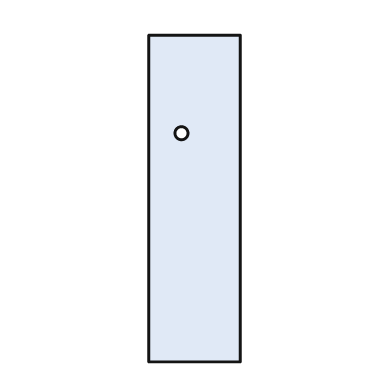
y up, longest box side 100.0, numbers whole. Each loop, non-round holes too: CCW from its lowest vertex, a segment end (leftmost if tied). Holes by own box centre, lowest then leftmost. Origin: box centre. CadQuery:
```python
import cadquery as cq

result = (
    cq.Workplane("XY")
    .moveTo(-14.0, -50.0)
    .lineTo(14.0, -50.0)
    .lineTo(14.0, 50.0)
    .lineTo(-14.0, 50.0)
    .close()
    .moveTo(-4.0, 20.0)
    .circle(2.0)
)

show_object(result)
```